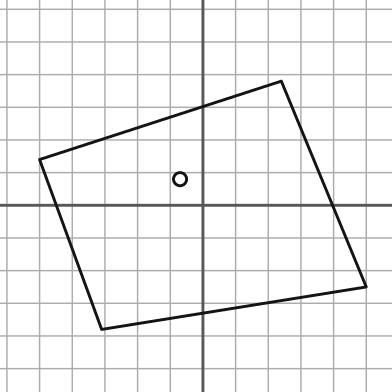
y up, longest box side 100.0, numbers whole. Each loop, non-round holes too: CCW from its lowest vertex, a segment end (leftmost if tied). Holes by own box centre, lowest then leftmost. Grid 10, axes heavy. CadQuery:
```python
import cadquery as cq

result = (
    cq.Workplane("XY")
    .moveTo(-31.0, -38.0)
    .lineTo(50.0, -25.0)
    .lineTo(24.0, 38.0)
    .lineTo(-50.0, 14.0)
    .close()
    .moveTo(-7.0, 8.0)
    .circle(2.0)
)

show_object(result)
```